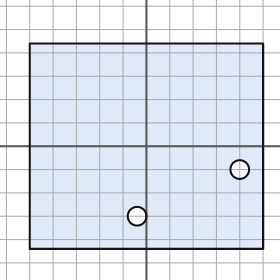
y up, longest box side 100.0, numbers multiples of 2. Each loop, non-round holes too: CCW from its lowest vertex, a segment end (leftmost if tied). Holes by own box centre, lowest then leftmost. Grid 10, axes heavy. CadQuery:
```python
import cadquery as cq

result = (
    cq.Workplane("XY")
    .moveTo(-50.0, -44.0)
    .lineTo(50.0, -44.0)
    .lineTo(50.0, 44.0)
    .lineTo(-50.0, 44.0)
    .close()
    .moveTo(-4.0, -30.0)
    .circle(4.0)
    .moveTo(40.0, -10.0)
    .circle(4.0)
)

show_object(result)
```